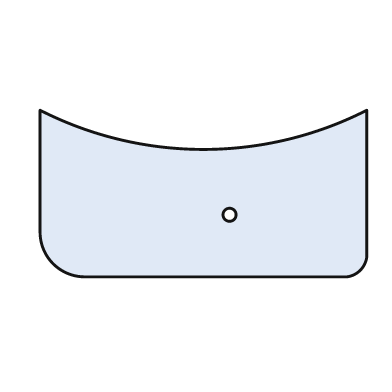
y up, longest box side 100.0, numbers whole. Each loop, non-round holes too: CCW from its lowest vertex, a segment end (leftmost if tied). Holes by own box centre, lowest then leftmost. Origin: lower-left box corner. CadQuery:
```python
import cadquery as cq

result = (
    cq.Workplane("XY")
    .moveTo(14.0, 0.0)
    .lineTo(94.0, 0.0)
    .threePointArc((98.0, 2.0), (100.0, 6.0))
    .lineTo(100.0, 51.0)
    .threePointArc((50.0, 39.0), (0.0, 51.0))
    .lineTo(0.0, 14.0)
    .threePointArc((4.0, 4.0), (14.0, 0.0))
    .close()
    .moveTo(58.0, 19.0)
    .circle(2.0)
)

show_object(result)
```